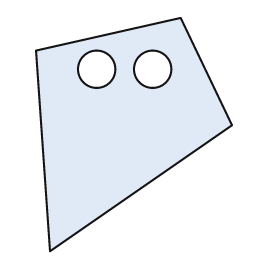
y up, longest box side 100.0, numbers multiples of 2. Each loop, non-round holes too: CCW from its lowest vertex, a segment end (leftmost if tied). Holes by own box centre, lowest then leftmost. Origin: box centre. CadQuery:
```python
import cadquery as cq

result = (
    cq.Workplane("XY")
    .moveTo(-36.0, -50.0)
    .lineTo(42.0, 4.0)
    .lineTo(20.0, 50.0)
    .lineTo(-42.0, 36.0)
    .close()
    .moveTo(-16.0, 28.0)
    .circle(8.0)
    .moveTo(8.0, 28.0)
    .circle(8.0)
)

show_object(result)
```